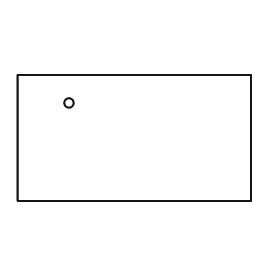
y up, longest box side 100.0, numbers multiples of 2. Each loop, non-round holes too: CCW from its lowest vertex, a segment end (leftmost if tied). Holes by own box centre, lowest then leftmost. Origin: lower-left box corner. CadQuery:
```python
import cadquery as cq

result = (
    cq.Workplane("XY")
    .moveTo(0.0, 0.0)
    .lineTo(100.0, 0.0)
    .lineTo(100.0, 54.0)
    .lineTo(0.0, 54.0)
    .close()
    .moveTo(22.0, 42.0)
    .circle(2.0)
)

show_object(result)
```